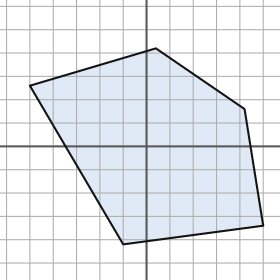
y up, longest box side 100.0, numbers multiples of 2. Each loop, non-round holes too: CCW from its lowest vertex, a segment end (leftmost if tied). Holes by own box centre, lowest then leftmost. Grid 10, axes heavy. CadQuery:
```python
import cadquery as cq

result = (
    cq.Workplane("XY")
    .moveTo(-10.0, -42.0)
    .lineTo(50.0, -34.0)
    .lineTo(42.0, 16.0)
    .lineTo(4.0, 42.0)
    .lineTo(-50.0, 26.0)
    .close()
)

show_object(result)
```